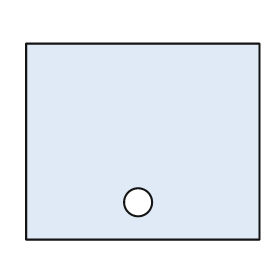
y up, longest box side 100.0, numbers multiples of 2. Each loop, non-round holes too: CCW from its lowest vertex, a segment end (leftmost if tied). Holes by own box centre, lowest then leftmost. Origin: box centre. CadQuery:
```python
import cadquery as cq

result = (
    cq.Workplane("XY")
    .moveTo(-50.0, -42.0)
    .lineTo(50.0, -42.0)
    .lineTo(50.0, 42.0)
    .lineTo(-50.0, 42.0)
    .close()
    .moveTo(-2.0, -26.0)
    .circle(6.0)
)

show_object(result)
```